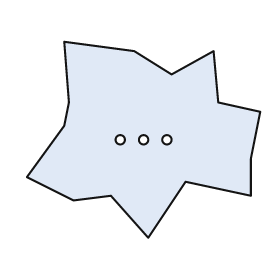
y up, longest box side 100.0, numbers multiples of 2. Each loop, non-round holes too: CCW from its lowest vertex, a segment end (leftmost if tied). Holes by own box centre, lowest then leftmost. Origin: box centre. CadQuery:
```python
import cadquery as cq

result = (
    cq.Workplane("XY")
    .moveTo(2.0, -42.0)
    .lineTo(18.0, -18.0)
    .lineTo(46.0, -24.0)
    .lineTo(46.0, -8.0)
    .lineTo(50.0, 12.0)
    .lineTo(32.0, 16.0)
    .lineTo(30.0, 38.0)
    .lineTo(12.0, 28.0)
    .lineTo(-4.0, 38.0)
    .lineTo(-34.0, 42.0)
    .lineTo(-32.0, 16.0)
    .lineTo(-34.0, 6.0)
    .lineTo(-50.0, -16.0)
    .lineTo(-30.0, -26.0)
    .lineTo(-14.0, -24.0)
    .close()
    .moveTo(-10.0, 0.0)
    .circle(2.0)
    .moveTo(0.0, 0.0)
    .circle(2.0)
    .moveTo(10.0, 0.0)
    .circle(2.0)
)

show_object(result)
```